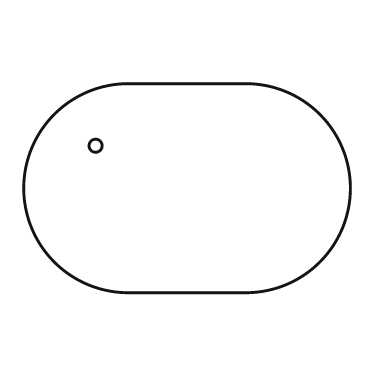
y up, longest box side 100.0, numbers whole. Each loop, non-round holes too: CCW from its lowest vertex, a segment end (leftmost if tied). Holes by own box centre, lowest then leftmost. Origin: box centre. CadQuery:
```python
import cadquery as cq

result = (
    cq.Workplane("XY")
    .moveTo(-18.0, -32.0)
    .lineTo(18.0, -32.0)
    .threePointArc((50.0, 0.0), (18.0, 32.0))
    .lineTo(-18.0, 32.0)
    .threePointArc((-50.0, 0.0), (-18.0, -32.0))
    .close()
    .moveTo(-28.0, 13.0)
    .circle(2.0)
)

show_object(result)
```